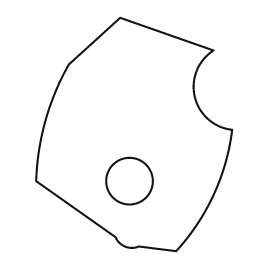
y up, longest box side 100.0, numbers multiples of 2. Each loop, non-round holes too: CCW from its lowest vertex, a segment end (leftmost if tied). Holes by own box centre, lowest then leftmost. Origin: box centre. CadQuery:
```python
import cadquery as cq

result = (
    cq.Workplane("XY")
    .moveTo(18.0, -50.0)
    .threePointArc((34.0, -26.0), (42.0, 2.0))
    .threePointArc((26.0, 16.0), (34.0, 36.0))
    .lineTo(-6.0, 50.0)
    .lineTo(-28.0, 30.0)
    .threePointArc((-38.0, 6.0), (-42.0, -20.0))
    .lineTo(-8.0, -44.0)
    .threePointArc((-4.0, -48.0), (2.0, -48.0))
    .close()
    .moveTo(-2.0, -20.0)
    .circle(10.0)
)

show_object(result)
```